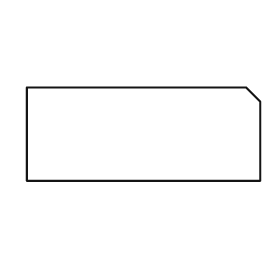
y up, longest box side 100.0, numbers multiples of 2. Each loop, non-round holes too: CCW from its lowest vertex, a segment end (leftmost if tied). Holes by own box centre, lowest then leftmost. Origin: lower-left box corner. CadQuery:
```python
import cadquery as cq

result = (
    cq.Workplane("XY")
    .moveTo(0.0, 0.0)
    .lineTo(100.0, 0.0)
    .lineTo(100.0, 34.0)
    .lineTo(94.0, 40.0)
    .lineTo(0.0, 40.0)
    .close()
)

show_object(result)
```